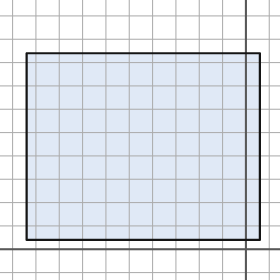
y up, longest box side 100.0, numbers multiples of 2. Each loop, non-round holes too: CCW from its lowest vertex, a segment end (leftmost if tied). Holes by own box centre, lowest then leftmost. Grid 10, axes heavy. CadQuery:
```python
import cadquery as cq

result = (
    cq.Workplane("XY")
    .moveTo(-94.0, 4.0)
    .lineTo(6.0, 4.0)
    .lineTo(6.0, 84.0)
    .lineTo(-94.0, 84.0)
    .close()
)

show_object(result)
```